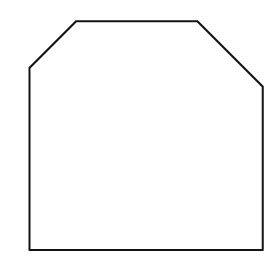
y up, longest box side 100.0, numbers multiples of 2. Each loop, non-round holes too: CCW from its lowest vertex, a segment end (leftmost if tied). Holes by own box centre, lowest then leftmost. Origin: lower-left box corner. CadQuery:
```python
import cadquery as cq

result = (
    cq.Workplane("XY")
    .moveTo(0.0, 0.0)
    .lineTo(100.0, 0.0)
    .lineTo(100.0, 70.0)
    .lineTo(72.0, 98.0)
    .lineTo(20.0, 98.0)
    .lineTo(0.0, 78.0)
    .close()
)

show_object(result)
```